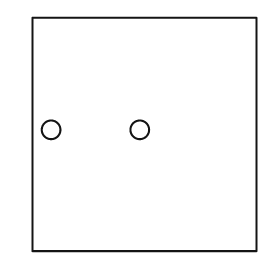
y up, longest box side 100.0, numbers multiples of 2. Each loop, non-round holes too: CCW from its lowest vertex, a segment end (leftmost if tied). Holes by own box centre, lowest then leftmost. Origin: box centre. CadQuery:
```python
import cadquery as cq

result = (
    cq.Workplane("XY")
    .moveTo(-48.0, -50.0)
    .lineTo(48.0, -50.0)
    .lineTo(48.0, 50.0)
    .lineTo(-48.0, 50.0)
    .close()
    .moveTo(-40.0, 2.0)
    .circle(4.0)
    .moveTo(-2.0, 2.0)
    .circle(4.0)
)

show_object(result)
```